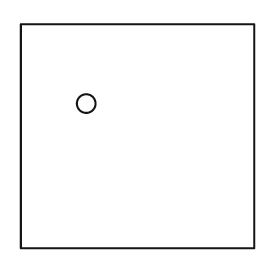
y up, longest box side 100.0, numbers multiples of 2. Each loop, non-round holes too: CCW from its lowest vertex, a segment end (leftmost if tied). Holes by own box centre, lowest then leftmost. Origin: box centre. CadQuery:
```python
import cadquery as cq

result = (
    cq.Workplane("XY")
    .moveTo(-50.0, -48.0)
    .lineTo(50.0, -48.0)
    .lineTo(50.0, 48.0)
    .lineTo(-50.0, 48.0)
    .close()
    .moveTo(-22.0, 14.0)
    .circle(4.0)
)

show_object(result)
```